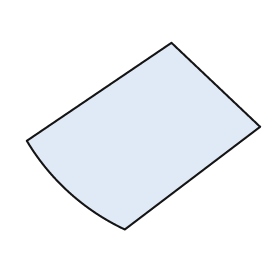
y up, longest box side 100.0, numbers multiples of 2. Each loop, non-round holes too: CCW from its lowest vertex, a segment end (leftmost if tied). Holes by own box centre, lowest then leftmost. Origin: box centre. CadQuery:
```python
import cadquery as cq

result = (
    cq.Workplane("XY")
    .moveTo(-8.0, -40.0)
    .lineTo(50.0, 4.0)
    .lineTo(12.0, 40.0)
    .lineTo(-50.0, -2.0)
    .threePointArc((-32.0, -24.0), (-8.0, -40.0))
    .close()
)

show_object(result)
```